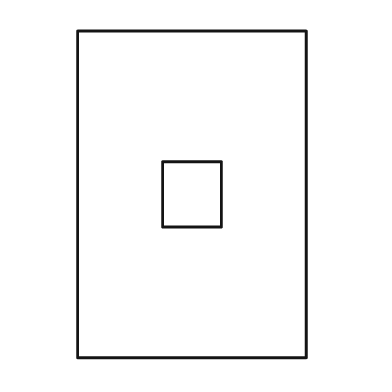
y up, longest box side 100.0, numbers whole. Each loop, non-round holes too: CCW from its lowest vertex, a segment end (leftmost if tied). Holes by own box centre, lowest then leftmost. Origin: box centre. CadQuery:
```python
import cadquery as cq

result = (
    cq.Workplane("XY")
    .moveTo(-35.0, -50.0)
    .lineTo(35.0, -50.0)
    .lineTo(35.0, 50.0)
    .lineTo(-35.0, 50.0)
    .close()
    .moveTo(-9.0, -10.0)
    .lineTo(9.0, -10.0)
    .lineTo(9.0, 10.0)
    .lineTo(-9.0, 10.0)
    .close()
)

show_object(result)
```